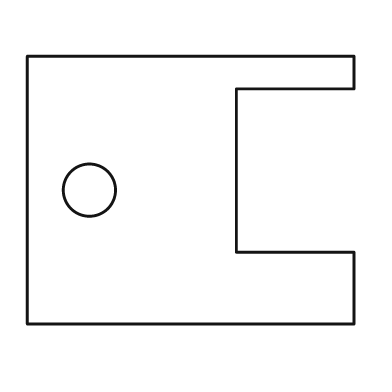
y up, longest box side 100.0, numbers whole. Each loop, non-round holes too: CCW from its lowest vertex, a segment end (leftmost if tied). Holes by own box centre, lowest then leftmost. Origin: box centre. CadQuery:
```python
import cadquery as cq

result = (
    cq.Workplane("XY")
    .moveTo(-50.0, -41.0)
    .lineTo(50.0, -41.0)
    .lineTo(50.0, -19.0)
    .lineTo(14.0, -19.0)
    .lineTo(14.0, 31.0)
    .lineTo(50.0, 31.0)
    .lineTo(50.0, 41.0)
    .lineTo(-50.0, 41.0)
    .close()
    .moveTo(-31.0, 0.0)
    .circle(8.0)
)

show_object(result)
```